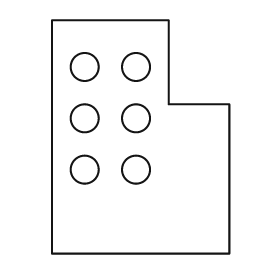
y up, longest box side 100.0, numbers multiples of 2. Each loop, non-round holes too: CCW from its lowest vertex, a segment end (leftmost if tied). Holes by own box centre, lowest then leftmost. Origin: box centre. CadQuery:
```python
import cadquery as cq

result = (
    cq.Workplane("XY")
    .moveTo(-38.0, -50.0)
    .lineTo(38.0, -50.0)
    .lineTo(38.0, 14.0)
    .lineTo(12.0, 14.0)
    .lineTo(12.0, 50.0)
    .lineTo(-38.0, 50.0)
    .close()
    .moveTo(-24.0, -14.0)
    .circle(6.0)
    .moveTo(-2.0, -14.0)
    .circle(6.0)
    .moveTo(-24.0, 8.0)
    .circle(6.0)
    .moveTo(-2.0, 8.0)
    .circle(6.0)
    .moveTo(-24.0, 30.0)
    .circle(6.0)
    .moveTo(-2.0, 30.0)
    .circle(6.0)
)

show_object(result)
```